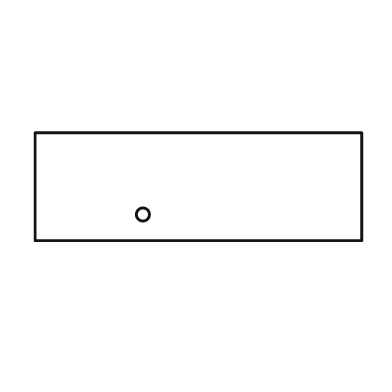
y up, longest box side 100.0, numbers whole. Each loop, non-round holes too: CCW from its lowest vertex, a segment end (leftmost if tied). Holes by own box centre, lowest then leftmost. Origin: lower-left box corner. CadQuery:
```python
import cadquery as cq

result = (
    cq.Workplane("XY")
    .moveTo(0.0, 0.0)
    .lineTo(100.0, 0.0)
    .lineTo(100.0, 33.0)
    .lineTo(0.0, 33.0)
    .close()
    .moveTo(33.0, 8.0)
    .circle(2.0)
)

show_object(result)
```